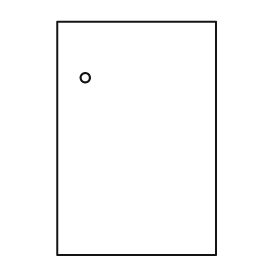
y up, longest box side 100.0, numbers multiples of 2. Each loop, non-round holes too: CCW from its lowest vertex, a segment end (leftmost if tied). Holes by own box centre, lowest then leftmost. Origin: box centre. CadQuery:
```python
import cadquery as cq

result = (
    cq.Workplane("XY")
    .moveTo(-34.0, -50.0)
    .lineTo(34.0, -50.0)
    .lineTo(34.0, 50.0)
    .lineTo(-34.0, 50.0)
    .close()
    .moveTo(-22.0, 26.0)
    .circle(2.0)
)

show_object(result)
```